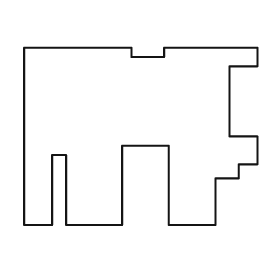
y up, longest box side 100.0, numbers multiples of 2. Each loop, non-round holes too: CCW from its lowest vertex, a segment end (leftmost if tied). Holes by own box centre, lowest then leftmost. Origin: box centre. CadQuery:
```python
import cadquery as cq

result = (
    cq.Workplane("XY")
    .moveTo(-50.0, -38.0)
    .lineTo(-38.0, -38.0)
    .lineTo(-38.0, -8.0)
    .lineTo(-32.0, -8.0)
    .lineTo(-32.0, -38.0)
    .lineTo(-8.0, -38.0)
    .lineTo(-8.0, -4.0)
    .lineTo(12.0, -4.0)
    .lineTo(12.0, -38.0)
    .lineTo(32.0, -38.0)
    .lineTo(32.0, -18.0)
    .lineTo(42.0, -18.0)
    .lineTo(42.0, -12.0)
    .lineTo(50.0, -12.0)
    .lineTo(50.0, 0.0)
    .lineTo(38.0, 0.0)
    .lineTo(38.0, 30.0)
    .lineTo(50.0, 30.0)
    .lineTo(50.0, 38.0)
    .lineTo(10.0, 38.0)
    .lineTo(10.0, 34.0)
    .lineTo(-4.0, 34.0)
    .lineTo(-4.0, 38.0)
    .lineTo(-50.0, 38.0)
    .close()
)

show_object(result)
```